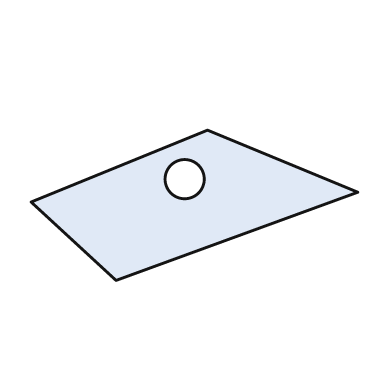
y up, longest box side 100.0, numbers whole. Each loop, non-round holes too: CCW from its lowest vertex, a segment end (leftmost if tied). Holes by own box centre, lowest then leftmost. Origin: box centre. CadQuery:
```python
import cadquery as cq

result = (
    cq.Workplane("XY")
    .moveTo(-24.0, -23.0)
    .lineTo(50.0, 4.0)
    .lineTo(4.0, 23.0)
    .lineTo(-50.0, 1.0)
    .close()
    .moveTo(-3.0, 8.0)
    .circle(6.0)
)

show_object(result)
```